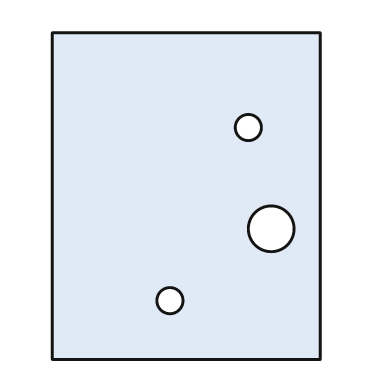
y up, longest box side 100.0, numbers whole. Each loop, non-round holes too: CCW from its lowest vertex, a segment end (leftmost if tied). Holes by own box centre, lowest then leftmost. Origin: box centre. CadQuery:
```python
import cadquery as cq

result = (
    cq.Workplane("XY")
    .moveTo(-41.0, -50.0)
    .lineTo(41.0, -50.0)
    .lineTo(41.0, 50.0)
    .lineTo(-41.0, 50.0)
    .close()
    .moveTo(-5.0, -32.0)
    .circle(4.0)
    .moveTo(26.0, -10.0)
    .circle(7.0)
    .moveTo(19.0, 21.0)
    .circle(4.0)
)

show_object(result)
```